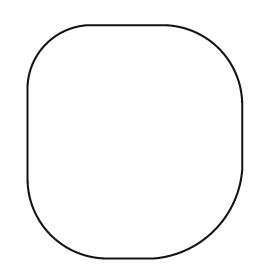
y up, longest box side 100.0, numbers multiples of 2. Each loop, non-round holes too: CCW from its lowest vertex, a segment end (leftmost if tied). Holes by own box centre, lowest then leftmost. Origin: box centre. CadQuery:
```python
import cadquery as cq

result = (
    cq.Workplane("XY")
    .moveTo(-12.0, -50.0)
    .lineTo(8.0, -50.0)
    .threePointArc((34.0, -38.0), (46.0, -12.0))
    .lineTo(46.0, 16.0)
    .threePointArc((36.0, 40.0), (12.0, 50.0))
    .lineTo(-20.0, 50.0)
    .threePointArc((-38.0, 42.0), (-46.0, 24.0))
    .lineTo(-46.0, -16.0)
    .threePointArc((-36.0, -40.0), (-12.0, -50.0))
    .close()
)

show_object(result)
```